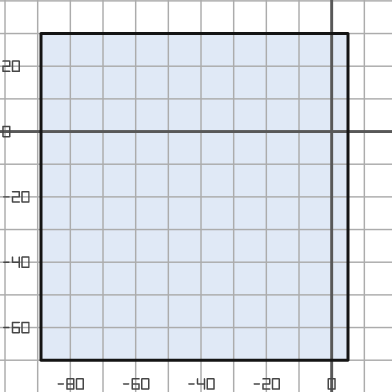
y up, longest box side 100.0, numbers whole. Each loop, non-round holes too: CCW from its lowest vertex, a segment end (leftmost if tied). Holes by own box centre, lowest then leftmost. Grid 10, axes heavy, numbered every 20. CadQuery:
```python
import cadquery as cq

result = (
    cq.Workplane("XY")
    .moveTo(-89.0, -70.0)
    .lineTo(5.0, -70.0)
    .lineTo(5.0, 30.0)
    .lineTo(-89.0, 30.0)
    .close()
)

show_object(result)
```